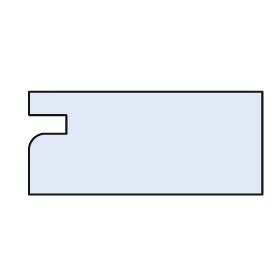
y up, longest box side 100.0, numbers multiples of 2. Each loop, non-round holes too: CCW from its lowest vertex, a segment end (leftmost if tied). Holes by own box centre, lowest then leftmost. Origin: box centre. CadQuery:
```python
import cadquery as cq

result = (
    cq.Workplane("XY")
    .moveTo(-50.0, -22.0)
    .lineTo(50.0, -22.0)
    .lineTo(50.0, 22.0)
    .lineTo(-50.0, 22.0)
    .lineTo(-50.0, 12.0)
    .lineTo(-34.0, 12.0)
    .lineTo(-34.0, 4.0)
    .lineTo(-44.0, 4.0)
    .threePointArc((-48.0, 2.0), (-50.0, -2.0))
    .close()
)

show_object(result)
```